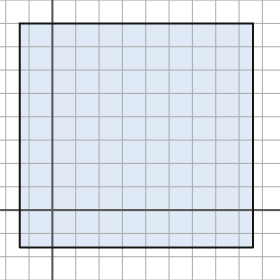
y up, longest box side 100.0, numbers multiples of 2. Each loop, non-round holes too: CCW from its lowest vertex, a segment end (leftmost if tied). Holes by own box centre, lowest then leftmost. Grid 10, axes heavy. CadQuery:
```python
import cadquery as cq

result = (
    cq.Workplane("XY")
    .moveTo(-14.0, -16.0)
    .lineTo(86.0, -16.0)
    .lineTo(86.0, 80.0)
    .lineTo(-14.0, 80.0)
    .close()
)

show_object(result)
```